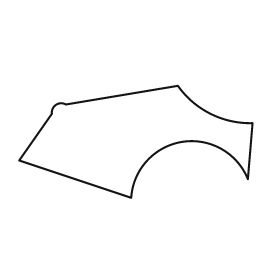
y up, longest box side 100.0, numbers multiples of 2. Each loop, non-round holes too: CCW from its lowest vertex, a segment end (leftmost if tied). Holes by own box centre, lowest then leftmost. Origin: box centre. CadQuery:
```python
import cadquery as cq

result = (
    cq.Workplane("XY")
    .moveTo(-2.0, -24.0)
    .threePointArc((20.0, 0.0), (48.0, -16.0))
    .lineTo(50.0, 8.0)
    .threePointArc((32.0, 12.0), (18.0, 24.0))
    .lineTo(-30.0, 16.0)
    .threePointArc((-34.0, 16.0), (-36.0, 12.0))
    .lineTo(-50.0, -8.0)
    .close()
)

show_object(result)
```